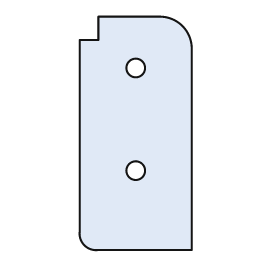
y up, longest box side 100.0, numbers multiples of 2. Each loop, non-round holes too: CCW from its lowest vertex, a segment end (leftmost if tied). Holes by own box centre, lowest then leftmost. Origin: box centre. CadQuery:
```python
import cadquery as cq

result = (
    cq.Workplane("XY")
    .moveTo(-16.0, -50.0)
    .lineTo(24.0, -50.0)
    .lineTo(24.0, 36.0)
    .threePointArc((20.0, 46.0), (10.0, 50.0))
    .lineTo(-16.0, 50.0)
    .lineTo(-16.0, 40.0)
    .lineTo(-24.0, 40.0)
    .lineTo(-24.0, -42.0)
    .threePointArc((-22.0, -48.0), (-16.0, -50.0))
    .close()
    .moveTo(0.0, -16.0)
    .circle(4.0)
    .moveTo(0.0, 28.0)
    .circle(4.0)
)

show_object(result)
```